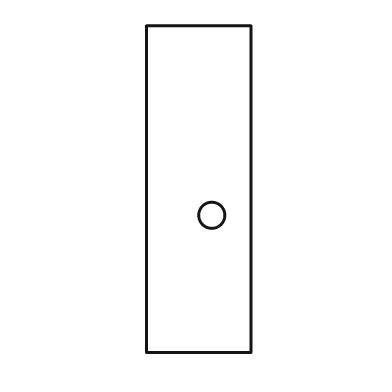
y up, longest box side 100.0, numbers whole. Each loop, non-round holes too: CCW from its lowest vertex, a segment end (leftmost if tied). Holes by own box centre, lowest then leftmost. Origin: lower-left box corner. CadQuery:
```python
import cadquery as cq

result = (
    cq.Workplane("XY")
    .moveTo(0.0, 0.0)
    .lineTo(32.0, 0.0)
    .lineTo(32.0, 100.0)
    .lineTo(0.0, 100.0)
    .close()
    .moveTo(20.0, 42.0)
    .circle(4.0)
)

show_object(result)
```